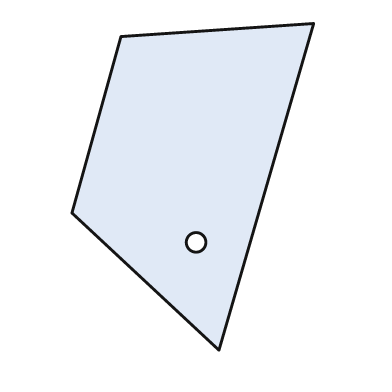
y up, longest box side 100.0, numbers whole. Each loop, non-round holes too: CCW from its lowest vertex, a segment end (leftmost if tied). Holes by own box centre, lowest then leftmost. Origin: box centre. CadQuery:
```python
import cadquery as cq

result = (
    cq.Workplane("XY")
    .moveTo(8.0, -50.0)
    .lineTo(37.0, 50.0)
    .lineTo(-22.0, 46.0)
    .lineTo(-37.0, -8.0)
    .close()
    .moveTo(1.0, -17.0)
    .circle(3.0)
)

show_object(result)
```